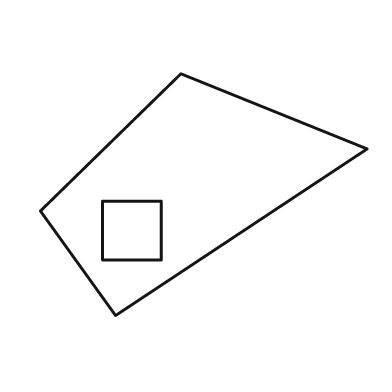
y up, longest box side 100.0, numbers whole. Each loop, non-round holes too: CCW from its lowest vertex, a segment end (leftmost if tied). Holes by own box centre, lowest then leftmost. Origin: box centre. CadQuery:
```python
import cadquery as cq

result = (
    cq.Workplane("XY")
    .moveTo(-27.0, -37.0)
    .lineTo(50.0, 14.0)
    .lineTo(-7.0, 37.0)
    .lineTo(-50.0, -5.0)
    .close()
    .moveTo(-31.0, -20.0)
    .lineTo(-13.0, -20.0)
    .lineTo(-13.0, -2.0)
    .lineTo(-31.0, -2.0)
    .close()
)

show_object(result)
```